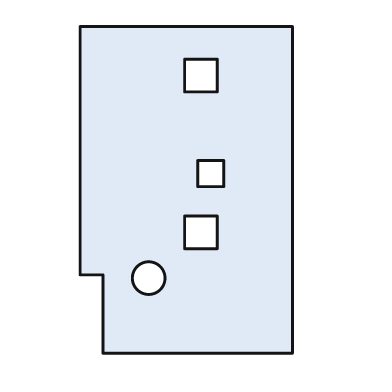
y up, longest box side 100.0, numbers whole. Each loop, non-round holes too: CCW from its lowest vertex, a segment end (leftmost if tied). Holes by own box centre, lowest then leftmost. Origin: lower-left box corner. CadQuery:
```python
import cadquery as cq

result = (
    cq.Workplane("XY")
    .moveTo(7.0, 0.0)
    .lineTo(65.0, 0.0)
    .lineTo(65.0, 100.0)
    .lineTo(0.0, 100.0)
    .lineTo(0.0, 24.0)
    .lineTo(7.0, 24.0)
    .close()
    .moveTo(21.0, 23.0)
    .circle(5.0)
    .moveTo(32.0, 32.0)
    .lineTo(42.0, 32.0)
    .lineTo(42.0, 42.0)
    .lineTo(32.0, 42.0)
    .close()
    .moveTo(36.0, 51.0)
    .lineTo(44.0, 51.0)
    .lineTo(44.0, 59.0)
    .lineTo(36.0, 59.0)
    .close()
    .moveTo(32.0, 80.0)
    .lineTo(42.0, 80.0)
    .lineTo(42.0, 90.0)
    .lineTo(32.0, 90.0)
    .close()
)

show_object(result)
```